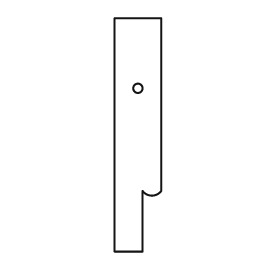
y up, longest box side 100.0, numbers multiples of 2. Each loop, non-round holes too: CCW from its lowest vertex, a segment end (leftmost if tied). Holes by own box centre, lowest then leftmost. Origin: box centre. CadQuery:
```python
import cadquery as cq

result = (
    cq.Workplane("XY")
    .moveTo(-10.0, -50.0)
    .lineTo(2.0, -50.0)
    .lineTo(2.0, -24.0)
    .threePointArc((6.0, -26.0), (10.0, -24.0))
    .lineTo(10.0, 50.0)
    .lineTo(-10.0, 50.0)
    .close()
    .moveTo(0.0, 20.0)
    .circle(2.0)
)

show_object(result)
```